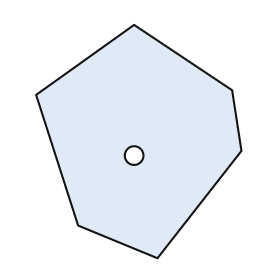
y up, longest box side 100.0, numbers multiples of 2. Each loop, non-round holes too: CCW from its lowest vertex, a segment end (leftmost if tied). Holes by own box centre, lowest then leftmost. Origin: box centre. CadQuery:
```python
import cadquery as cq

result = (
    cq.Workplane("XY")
    .moveTo(8.0, -50.0)
    .lineTo(44.0, -4.0)
    .lineTo(40.0, 22.0)
    .lineTo(-2.0, 50.0)
    .lineTo(-44.0, 20.0)
    .lineTo(-26.0, -36.0)
    .close()
    .moveTo(-2.0, -6.0)
    .circle(4.0)
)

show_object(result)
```